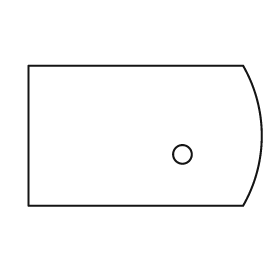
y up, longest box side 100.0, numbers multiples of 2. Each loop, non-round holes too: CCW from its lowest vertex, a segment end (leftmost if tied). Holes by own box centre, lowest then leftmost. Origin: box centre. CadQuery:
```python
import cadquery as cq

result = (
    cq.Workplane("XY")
    .moveTo(-50.0, -30.0)
    .lineTo(42.0, -30.0)
    .threePointArc((50.0, 0.0), (42.0, 30.0))
    .lineTo(-50.0, 30.0)
    .close()
    .moveTo(16.0, -8.0)
    .circle(4.0)
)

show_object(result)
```